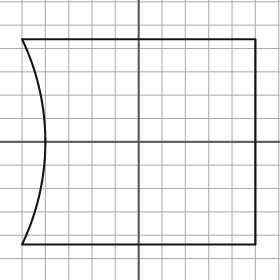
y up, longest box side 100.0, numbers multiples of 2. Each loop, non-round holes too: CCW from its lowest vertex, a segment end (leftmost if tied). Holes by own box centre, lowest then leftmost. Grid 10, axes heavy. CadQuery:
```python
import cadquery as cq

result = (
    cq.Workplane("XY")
    .moveTo(-50.0, -44.0)
    .lineTo(50.0, -44.0)
    .lineTo(50.0, 44.0)
    .lineTo(-50.0, 44.0)
    .threePointArc((-40.0, 0.0), (-50.0, -44.0))
    .close()
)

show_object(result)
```